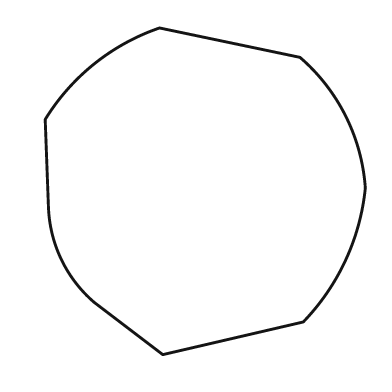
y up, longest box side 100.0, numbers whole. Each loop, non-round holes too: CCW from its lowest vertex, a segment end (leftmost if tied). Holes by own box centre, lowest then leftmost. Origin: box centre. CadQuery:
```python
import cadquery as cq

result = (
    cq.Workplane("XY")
    .moveTo(-13.0, -50.0)
    .lineTo(30.0, -40.0)
    .threePointArc((43.0, -21.0), (49.0, 1.0))
    .threePointArc((43.0, 23.0), (29.0, 41.0))
    .lineTo(-14.0, 50.0)
    .threePointArc((-34.0, 39.0), (-49.0, 22.0))
    .lineTo(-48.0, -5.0)
    .threePointArc((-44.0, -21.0), (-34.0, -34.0))
    .close()
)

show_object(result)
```